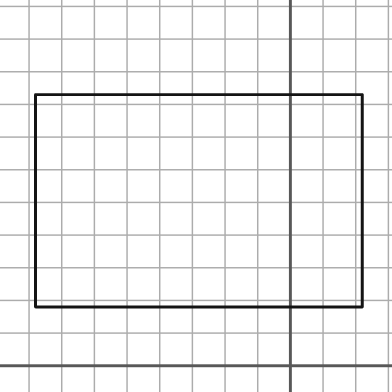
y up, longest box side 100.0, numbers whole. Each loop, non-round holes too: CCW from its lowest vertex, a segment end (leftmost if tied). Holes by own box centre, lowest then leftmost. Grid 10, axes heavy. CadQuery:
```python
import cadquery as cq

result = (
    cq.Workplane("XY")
    .moveTo(-78.0, 18.0)
    .lineTo(22.0, 18.0)
    .lineTo(22.0, 83.0)
    .lineTo(-78.0, 83.0)
    .close()
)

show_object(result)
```